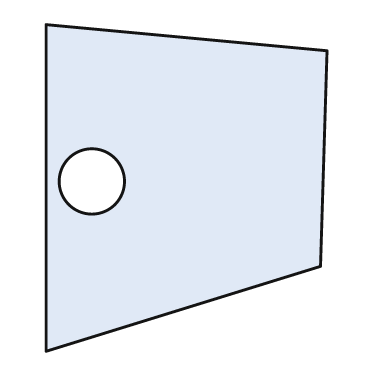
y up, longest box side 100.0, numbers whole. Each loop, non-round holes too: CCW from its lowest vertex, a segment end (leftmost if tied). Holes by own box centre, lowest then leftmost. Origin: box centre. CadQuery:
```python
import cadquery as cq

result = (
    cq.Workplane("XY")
    .moveTo(-43.0, -50.0)
    .lineTo(41.0, -24.0)
    .lineTo(43.0, 42.0)
    .lineTo(-43.0, 50.0)
    .close()
    .moveTo(-29.0, 2.0)
    .circle(10.0)
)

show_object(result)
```